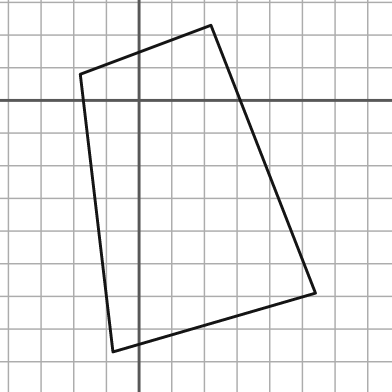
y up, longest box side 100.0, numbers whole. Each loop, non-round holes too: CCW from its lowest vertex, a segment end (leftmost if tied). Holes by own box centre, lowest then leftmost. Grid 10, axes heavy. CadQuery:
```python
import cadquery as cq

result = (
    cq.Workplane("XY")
    .moveTo(-8.0, -77.0)
    .lineTo(54.0, -59.0)
    .lineTo(22.0, 23.0)
    .lineTo(-18.0, 8.0)
    .close()
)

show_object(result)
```